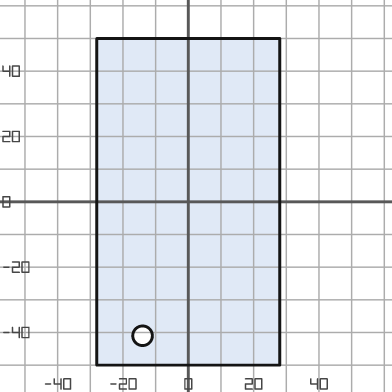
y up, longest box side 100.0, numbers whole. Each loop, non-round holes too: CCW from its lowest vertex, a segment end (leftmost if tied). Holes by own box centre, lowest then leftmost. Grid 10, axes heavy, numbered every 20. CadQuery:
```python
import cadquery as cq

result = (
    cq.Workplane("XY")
    .moveTo(-28.0, -50.0)
    .lineTo(28.0, -50.0)
    .lineTo(28.0, 50.0)
    .lineTo(-28.0, 50.0)
    .close()
    .moveTo(-14.0, -41.0)
    .circle(3.0)
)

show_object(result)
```